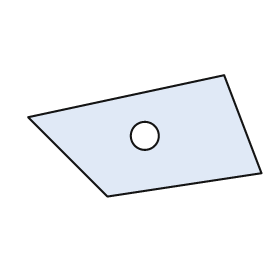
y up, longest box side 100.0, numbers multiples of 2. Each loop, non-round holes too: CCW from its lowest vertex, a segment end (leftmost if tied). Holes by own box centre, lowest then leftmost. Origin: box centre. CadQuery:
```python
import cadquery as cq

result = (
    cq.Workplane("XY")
    .moveTo(-16.0, -26.0)
    .lineTo(50.0, -16.0)
    .lineTo(34.0, 26.0)
    .lineTo(-50.0, 8.0)
    .close()
    .moveTo(0.0, 0.0)
    .circle(6.0)
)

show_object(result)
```